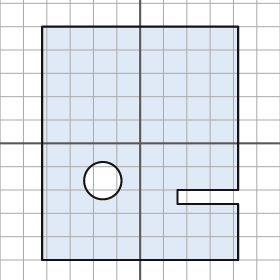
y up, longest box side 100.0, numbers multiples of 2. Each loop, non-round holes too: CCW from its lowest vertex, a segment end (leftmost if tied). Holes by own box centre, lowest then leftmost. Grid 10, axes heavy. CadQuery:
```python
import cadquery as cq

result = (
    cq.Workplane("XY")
    .moveTo(-42.0, -50.0)
    .lineTo(42.0, -50.0)
    .lineTo(42.0, -26.0)
    .lineTo(16.0, -26.0)
    .lineTo(16.0, -20.0)
    .lineTo(42.0, -20.0)
    .lineTo(42.0, 50.0)
    .lineTo(-42.0, 50.0)
    .close()
    .moveTo(-16.0, -16.0)
    .circle(8.0)
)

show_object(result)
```